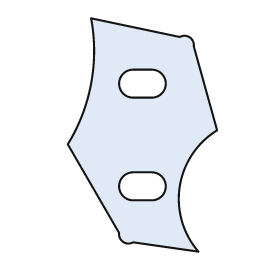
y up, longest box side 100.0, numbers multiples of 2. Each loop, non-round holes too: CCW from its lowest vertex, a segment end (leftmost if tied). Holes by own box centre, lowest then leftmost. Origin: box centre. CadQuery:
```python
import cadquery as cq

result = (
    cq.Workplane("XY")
    .moveTo(24.0, -50.0)
    .threePointArc((16.0, -22.0), (32.0, 2.0))
    .lineTo(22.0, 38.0)
    .threePointArc((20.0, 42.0), (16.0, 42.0))
    .lineTo(-22.0, 50.0)
    .threePointArc((-22.0, 22.0), (-32.0, -4.0))
    .lineTo(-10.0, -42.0)
    .threePointArc((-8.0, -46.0), (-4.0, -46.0))
    .close()
    .moveTo(-4.0, -28.0)
    .lineTo(4.0, -28.0)
    .threePointArc((10.0, -22.0), (4.0, -16.0))
    .lineTo(-4.0, -16.0)
    .threePointArc((-10.0, -22.0), (-4.0, -28.0))
    .close()
    .moveTo(-4.0, 16.0)
    .lineTo(4.0, 16.0)
    .threePointArc((10.0, 22.0), (4.0, 28.0))
    .lineTo(-4.0, 28.0)
    .threePointArc((-10.0, 22.0), (-4.0, 16.0))
    .close()
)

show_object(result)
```